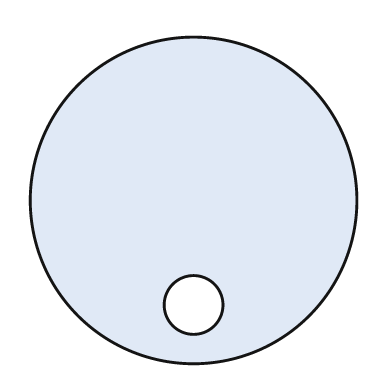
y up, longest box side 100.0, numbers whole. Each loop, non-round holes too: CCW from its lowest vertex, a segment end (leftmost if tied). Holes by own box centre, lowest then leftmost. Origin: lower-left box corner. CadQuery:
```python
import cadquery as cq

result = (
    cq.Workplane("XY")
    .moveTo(50.0, 50.0)
    .circle(50.0)
    .moveTo(50.0, 18.0)
    .circle(9.0)
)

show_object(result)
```